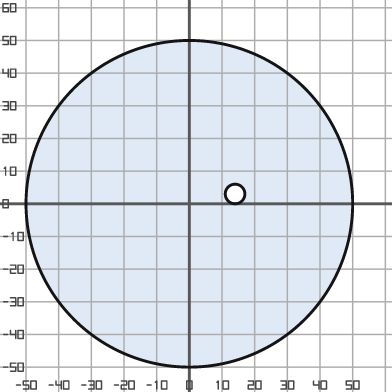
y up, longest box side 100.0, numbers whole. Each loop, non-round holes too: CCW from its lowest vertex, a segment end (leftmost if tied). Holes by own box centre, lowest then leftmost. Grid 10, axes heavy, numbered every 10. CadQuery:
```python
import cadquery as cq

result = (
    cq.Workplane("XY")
    .moveTo(0.0, 0.0)
    .circle(50.0)
    .moveTo(14.0, 3.0)
    .circle(3.0)
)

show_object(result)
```